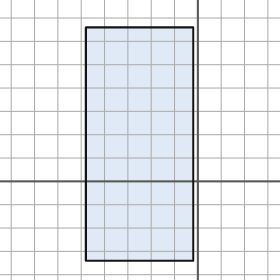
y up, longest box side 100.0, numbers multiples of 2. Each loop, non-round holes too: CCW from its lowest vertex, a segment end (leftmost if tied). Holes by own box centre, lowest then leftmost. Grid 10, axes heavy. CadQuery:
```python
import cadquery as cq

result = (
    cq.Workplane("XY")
    .moveTo(-48.0, -34.0)
    .lineTo(-2.0, -34.0)
    .lineTo(-2.0, 66.0)
    .lineTo(-48.0, 66.0)
    .close()
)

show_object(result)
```